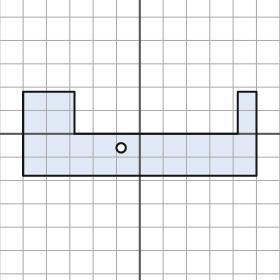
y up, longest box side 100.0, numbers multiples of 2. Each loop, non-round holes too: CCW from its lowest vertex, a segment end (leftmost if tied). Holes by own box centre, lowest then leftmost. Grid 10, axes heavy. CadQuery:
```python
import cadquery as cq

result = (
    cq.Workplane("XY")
    .moveTo(-50.0, -18.0)
    .lineTo(50.0, -18.0)
    .lineTo(50.0, 18.0)
    .lineTo(42.0, 18.0)
    .lineTo(42.0, 0.0)
    .lineTo(-28.0, 0.0)
    .lineTo(-28.0, 18.0)
    .lineTo(-50.0, 18.0)
    .close()
    .moveTo(-8.0, -6.0)
    .circle(2.0)
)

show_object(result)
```